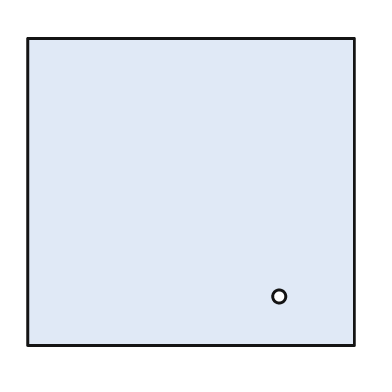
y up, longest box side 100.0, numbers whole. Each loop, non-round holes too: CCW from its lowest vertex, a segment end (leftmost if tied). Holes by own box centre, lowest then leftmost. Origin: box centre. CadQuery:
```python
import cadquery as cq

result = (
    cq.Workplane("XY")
    .moveTo(-50.0, -47.0)
    .lineTo(50.0, -47.0)
    .lineTo(50.0, 47.0)
    .lineTo(-50.0, 47.0)
    .close()
    .moveTo(27.0, -32.0)
    .circle(2.0)
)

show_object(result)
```